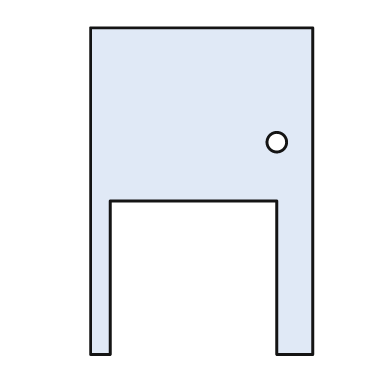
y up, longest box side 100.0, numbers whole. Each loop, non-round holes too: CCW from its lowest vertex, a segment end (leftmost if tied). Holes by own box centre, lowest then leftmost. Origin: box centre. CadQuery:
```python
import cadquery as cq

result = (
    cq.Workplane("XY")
    .moveTo(-34.0, -50.0)
    .lineTo(-28.0, -50.0)
    .lineTo(-28.0, -3.0)
    .lineTo(23.0, -3.0)
    .lineTo(23.0, -50.0)
    .lineTo(34.0, -50.0)
    .lineTo(34.0, 50.0)
    .lineTo(-34.0, 50.0)
    .close()
    .moveTo(23.0, 15.0)
    .circle(3.0)
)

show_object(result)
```